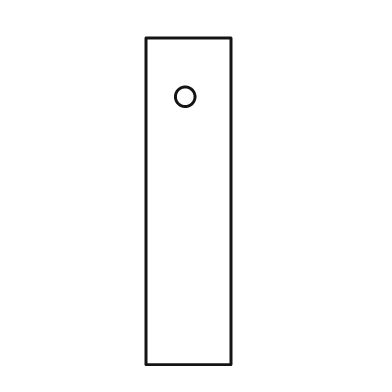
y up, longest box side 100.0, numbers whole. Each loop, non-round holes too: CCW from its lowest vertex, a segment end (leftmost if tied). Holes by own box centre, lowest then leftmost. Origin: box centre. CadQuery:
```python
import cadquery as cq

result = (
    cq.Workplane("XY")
    .moveTo(-13.0, -50.0)
    .lineTo(13.0, -50.0)
    .lineTo(13.0, 50.0)
    .lineTo(-13.0, 50.0)
    .close()
    .moveTo(-1.0, 32.0)
    .circle(3.0)
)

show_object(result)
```